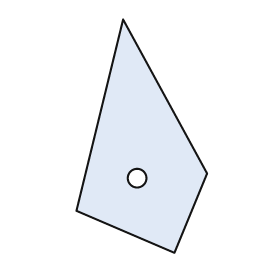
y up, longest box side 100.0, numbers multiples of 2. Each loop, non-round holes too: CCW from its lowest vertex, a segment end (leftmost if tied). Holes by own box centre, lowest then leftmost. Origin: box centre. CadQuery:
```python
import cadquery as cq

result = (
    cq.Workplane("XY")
    .moveTo(14.0, -50.0)
    .lineTo(28.0, -16.0)
    .lineTo(-8.0, 50.0)
    .lineTo(-28.0, -32.0)
    .close()
    .moveTo(-2.0, -18.0)
    .circle(4.0)
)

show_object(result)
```